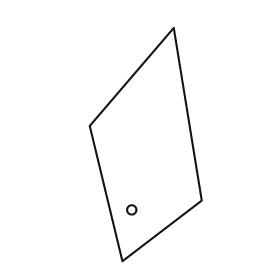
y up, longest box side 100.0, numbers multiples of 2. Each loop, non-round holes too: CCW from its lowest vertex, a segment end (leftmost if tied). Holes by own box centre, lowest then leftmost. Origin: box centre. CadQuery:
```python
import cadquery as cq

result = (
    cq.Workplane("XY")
    .moveTo(-10.0, -50.0)
    .lineTo(24.0, -24.0)
    .lineTo(12.0, 50.0)
    .lineTo(-24.0, 8.0)
    .close()
    .moveTo(-6.0, -28.0)
    .circle(2.0)
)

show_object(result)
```